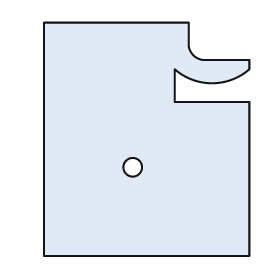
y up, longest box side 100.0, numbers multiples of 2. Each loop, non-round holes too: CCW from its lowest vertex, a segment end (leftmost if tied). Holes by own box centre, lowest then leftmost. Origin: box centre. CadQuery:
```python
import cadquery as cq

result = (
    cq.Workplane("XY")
    .moveTo(-44.0, -50.0)
    .lineTo(44.0, -50.0)
    .lineTo(44.0, 16.0)
    .lineTo(12.0, 16.0)
    .lineTo(12.0, 30.0)
    .threePointArc((28.0, 24.0), (44.0, 30.0))
    .lineTo(44.0, 34.0)
    .lineTo(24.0, 34.0)
    .threePointArc((20.0, 36.0), (18.0, 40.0))
    .lineTo(18.0, 50.0)
    .lineTo(-44.0, 50.0)
    .close()
    .moveTo(-6.0, -12.0)
    .circle(4.0)
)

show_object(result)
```